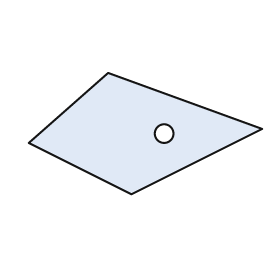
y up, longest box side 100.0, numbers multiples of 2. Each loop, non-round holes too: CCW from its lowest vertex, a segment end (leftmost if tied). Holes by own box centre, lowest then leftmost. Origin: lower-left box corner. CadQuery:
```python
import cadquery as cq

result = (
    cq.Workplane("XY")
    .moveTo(44.0, 0.0)
    .lineTo(100.0, 28.0)
    .lineTo(34.0, 52.0)
    .lineTo(0.0, 22.0)
    .close()
    .moveTo(58.0, 26.0)
    .circle(4.0)
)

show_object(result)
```